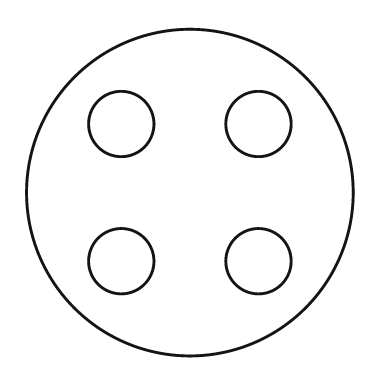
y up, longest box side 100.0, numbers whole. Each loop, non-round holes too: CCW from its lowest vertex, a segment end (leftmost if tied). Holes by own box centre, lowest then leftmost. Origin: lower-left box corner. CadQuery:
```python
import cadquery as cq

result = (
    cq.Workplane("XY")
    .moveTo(50.0, 50.0)
    .circle(50.0)
    .moveTo(29.0, 29.0)
    .circle(10.0)
    .moveTo(71.0, 29.0)
    .circle(10.0)
    .moveTo(29.0, 71.0)
    .circle(10.0)
    .moveTo(71.0, 71.0)
    .circle(10.0)
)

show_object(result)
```